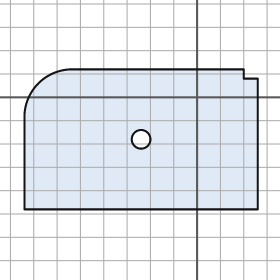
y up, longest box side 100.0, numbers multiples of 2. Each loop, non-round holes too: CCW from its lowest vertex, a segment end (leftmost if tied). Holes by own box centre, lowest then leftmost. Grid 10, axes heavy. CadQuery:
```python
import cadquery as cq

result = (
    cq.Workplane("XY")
    .moveTo(-74.0, -48.0)
    .lineTo(26.0, -48.0)
    .lineTo(26.0, 8.0)
    .lineTo(20.0, 8.0)
    .lineTo(20.0, 12.0)
    .lineTo(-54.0, 12.0)
    .threePointArc((-68.0, 6.0), (-74.0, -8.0))
    .close()
    .moveTo(-24.0, -18.0)
    .circle(4.0)
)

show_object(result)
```